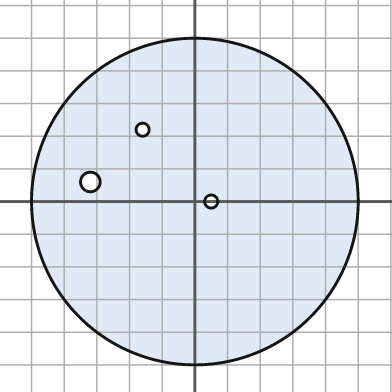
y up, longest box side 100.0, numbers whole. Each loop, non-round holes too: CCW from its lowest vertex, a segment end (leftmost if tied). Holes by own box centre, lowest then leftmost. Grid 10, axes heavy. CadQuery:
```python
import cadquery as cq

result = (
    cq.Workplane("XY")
    .moveTo(0.0, 0.0)
    .circle(50.0)
    .moveTo(5.0, 0.0)
    .circle(2.0)
    .moveTo(-32.0, 6.0)
    .circle(3.0)
    .moveTo(-16.0, 22.0)
    .circle(2.0)
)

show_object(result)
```